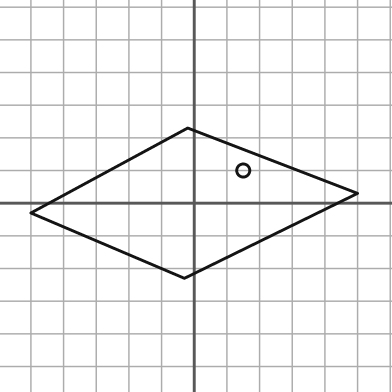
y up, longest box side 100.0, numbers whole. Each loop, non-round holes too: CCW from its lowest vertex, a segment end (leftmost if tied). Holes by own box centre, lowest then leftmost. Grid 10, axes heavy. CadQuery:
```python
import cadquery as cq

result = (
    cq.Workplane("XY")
    .moveTo(-3.0, -23.0)
    .lineTo(50.0, 3.0)
    .lineTo(-2.0, 23.0)
    .lineTo(-50.0, -3.0)
    .close()
    .moveTo(15.0, 10.0)
    .circle(2.0)
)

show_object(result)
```